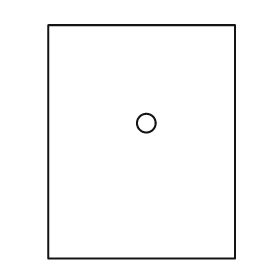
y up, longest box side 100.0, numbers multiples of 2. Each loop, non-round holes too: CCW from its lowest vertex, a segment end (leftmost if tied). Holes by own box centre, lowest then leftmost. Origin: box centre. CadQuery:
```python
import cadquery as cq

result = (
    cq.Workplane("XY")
    .moveTo(-40.0, -50.0)
    .lineTo(40.0, -50.0)
    .lineTo(40.0, 50.0)
    .lineTo(-40.0, 50.0)
    .close()
    .moveTo(2.0, 8.0)
    .circle(4.0)
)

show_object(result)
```